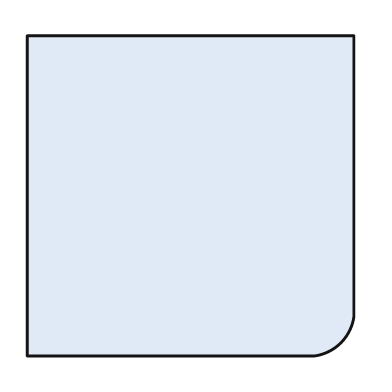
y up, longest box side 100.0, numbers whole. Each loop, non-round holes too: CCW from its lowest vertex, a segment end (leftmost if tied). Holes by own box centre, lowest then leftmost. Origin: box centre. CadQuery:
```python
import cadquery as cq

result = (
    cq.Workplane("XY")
    .moveTo(-50.0, -49.0)
    .lineTo(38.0, -49.0)
    .threePointArc((46.0, -45.0), (50.0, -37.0))
    .lineTo(50.0, 49.0)
    .lineTo(-50.0, 49.0)
    .close()
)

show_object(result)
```